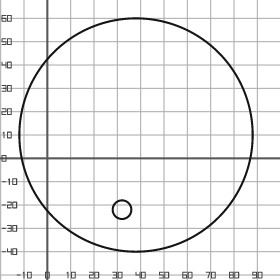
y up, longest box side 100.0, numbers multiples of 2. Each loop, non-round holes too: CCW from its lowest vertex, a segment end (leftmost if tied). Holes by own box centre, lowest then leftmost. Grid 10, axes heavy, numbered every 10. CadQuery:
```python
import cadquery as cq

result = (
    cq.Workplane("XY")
    .moveTo(38.0, 10.0)
    .circle(50.0)
    .moveTo(32.0, -22.0)
    .circle(4.0)
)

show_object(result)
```